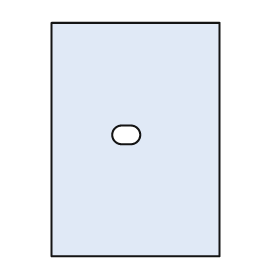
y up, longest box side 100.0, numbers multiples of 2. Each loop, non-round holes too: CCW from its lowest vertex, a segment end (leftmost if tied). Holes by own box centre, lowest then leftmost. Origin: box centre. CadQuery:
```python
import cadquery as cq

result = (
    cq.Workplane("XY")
    .moveTo(-36.0, -50.0)
    .lineTo(36.0, -50.0)
    .lineTo(36.0, 50.0)
    .lineTo(-36.0, 50.0)
    .close()
    .moveTo(-6.0, -2.0)
    .lineTo(-2.0, -2.0)
    .threePointArc((2.0, 2.0), (-2.0, 6.0))
    .lineTo(-6.0, 6.0)
    .threePointArc((-10.0, 2.0), (-6.0, -2.0))
    .close()
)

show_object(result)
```